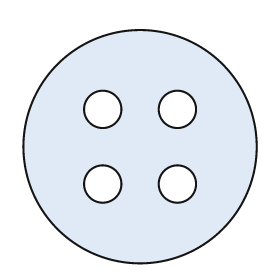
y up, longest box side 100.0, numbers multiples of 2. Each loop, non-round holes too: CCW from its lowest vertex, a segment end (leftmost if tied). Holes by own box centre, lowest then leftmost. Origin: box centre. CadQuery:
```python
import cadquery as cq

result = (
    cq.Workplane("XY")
    .moveTo(0.0, 0.0)
    .circle(50.0)
    .moveTo(-16.0, -16.0)
    .circle(8.0)
    .moveTo(16.0, -16.0)
    .circle(8.0)
    .moveTo(-16.0, 16.0)
    .circle(8.0)
    .moveTo(16.0, 16.0)
    .circle(8.0)
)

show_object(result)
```